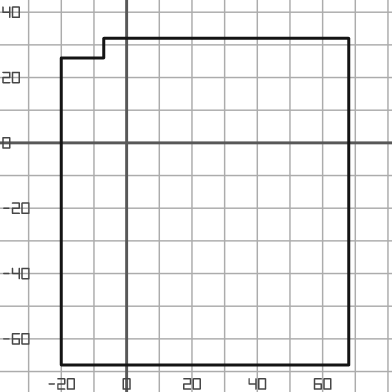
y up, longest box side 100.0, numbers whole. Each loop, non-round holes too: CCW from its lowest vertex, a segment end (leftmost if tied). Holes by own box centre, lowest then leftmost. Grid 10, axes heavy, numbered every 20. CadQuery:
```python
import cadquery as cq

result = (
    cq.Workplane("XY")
    .moveTo(-20.0, -68.0)
    .lineTo(68.0, -68.0)
    .lineTo(68.0, 32.0)
    .lineTo(-7.0, 32.0)
    .lineTo(-7.0, 26.0)
    .lineTo(-20.0, 26.0)
    .close()
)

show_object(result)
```